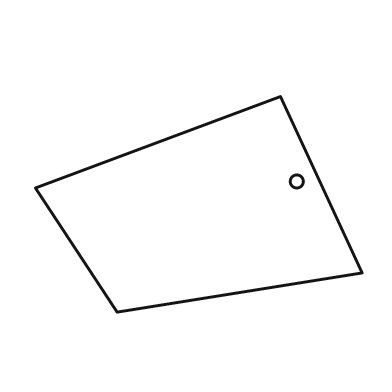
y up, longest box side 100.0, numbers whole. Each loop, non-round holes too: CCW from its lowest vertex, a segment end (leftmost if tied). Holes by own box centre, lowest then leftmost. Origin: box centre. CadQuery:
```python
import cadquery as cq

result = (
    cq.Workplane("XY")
    .moveTo(-25.0, -33.0)
    .lineTo(50.0, -21.0)
    .lineTo(25.0, 33.0)
    .lineTo(-50.0, 5.0)
    .close()
    .moveTo(30.0, 7.0)
    .circle(2.0)
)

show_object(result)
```